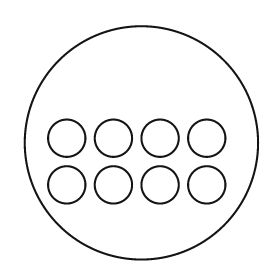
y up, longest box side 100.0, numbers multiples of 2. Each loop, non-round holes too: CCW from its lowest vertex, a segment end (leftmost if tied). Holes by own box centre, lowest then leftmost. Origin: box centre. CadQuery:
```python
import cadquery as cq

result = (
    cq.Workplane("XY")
    .moveTo(0.0, 0.0)
    .circle(50.0)
    .moveTo(-32.0, -18.0)
    .circle(8.0)
    .moveTo(-12.0, -18.0)
    .circle(8.0)
    .moveTo(8.0, -18.0)
    .circle(8.0)
    .moveTo(28.0, -18.0)
    .circle(8.0)
    .moveTo(-32.0, 2.0)
    .circle(8.0)
    .moveTo(-12.0, 2.0)
    .circle(8.0)
    .moveTo(8.0, 2.0)
    .circle(8.0)
    .moveTo(28.0, 2.0)
    .circle(8.0)
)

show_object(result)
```